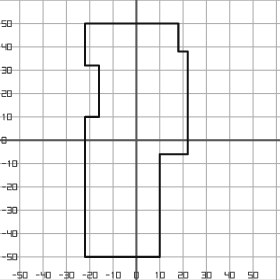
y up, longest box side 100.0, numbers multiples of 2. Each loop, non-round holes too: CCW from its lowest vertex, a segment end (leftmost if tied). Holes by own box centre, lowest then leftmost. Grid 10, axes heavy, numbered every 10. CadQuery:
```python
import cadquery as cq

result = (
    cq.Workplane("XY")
    .moveTo(-22.0, -50.0)
    .lineTo(10.0, -50.0)
    .lineTo(10.0, -6.0)
    .lineTo(22.0, -6.0)
    .lineTo(22.0, 38.0)
    .lineTo(18.0, 38.0)
    .lineTo(18.0, 50.0)
    .lineTo(-22.0, 50.0)
    .lineTo(-22.0, 32.0)
    .lineTo(-16.0, 32.0)
    .lineTo(-16.0, 10.0)
    .lineTo(-22.0, 10.0)
    .close()
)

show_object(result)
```